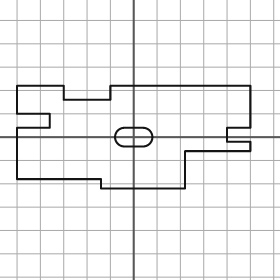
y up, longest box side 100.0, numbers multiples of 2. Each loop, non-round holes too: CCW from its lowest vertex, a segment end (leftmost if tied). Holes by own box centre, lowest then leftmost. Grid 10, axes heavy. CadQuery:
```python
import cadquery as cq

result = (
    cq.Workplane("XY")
    .moveTo(-14.0, -22.0)
    .lineTo(22.0, -22.0)
    .lineTo(22.0, -6.0)
    .lineTo(50.0, -6.0)
    .lineTo(50.0, -2.0)
    .lineTo(40.0, -2.0)
    .lineTo(40.0, 4.0)
    .lineTo(50.0, 4.0)
    .lineTo(50.0, 22.0)
    .lineTo(-10.0, 22.0)
    .lineTo(-10.0, 16.0)
    .lineTo(-30.0, 16.0)
    .lineTo(-30.0, 22.0)
    .lineTo(-50.0, 22.0)
    .lineTo(-50.0, 10.0)
    .lineTo(-36.0, 10.0)
    .lineTo(-36.0, 4.0)
    .lineTo(-50.0, 4.0)
    .lineTo(-50.0, -18.0)
    .lineTo(-14.0, -18.0)
    .close()
    .moveTo(-4.0, -4.0)
    .lineTo(4.0, -4.0)
    .threePointArc((8.0, 0.0), (4.0, 4.0))
    .lineTo(-4.0, 4.0)
    .threePointArc((-8.0, 0.0), (-4.0, -4.0))
    .close()
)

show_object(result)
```